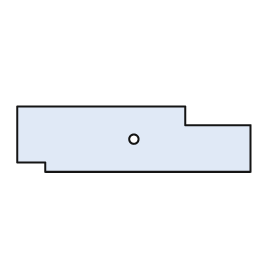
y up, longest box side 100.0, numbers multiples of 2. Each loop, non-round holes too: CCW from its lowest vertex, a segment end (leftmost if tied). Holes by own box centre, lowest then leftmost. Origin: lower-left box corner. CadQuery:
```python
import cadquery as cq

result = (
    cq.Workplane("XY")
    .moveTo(12.0, 0.0)
    .lineTo(100.0, 0.0)
    .lineTo(100.0, 20.0)
    .lineTo(72.0, 20.0)
    .lineTo(72.0, 28.0)
    .lineTo(0.0, 28.0)
    .lineTo(0.0, 4.0)
    .lineTo(12.0, 4.0)
    .close()
    .moveTo(50.0, 14.0)
    .circle(2.0)
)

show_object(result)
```